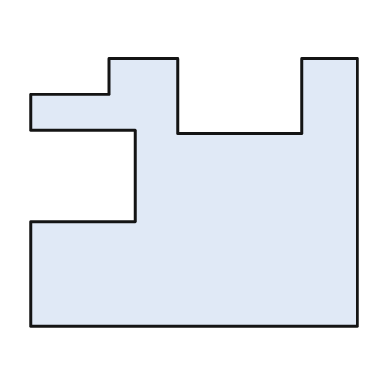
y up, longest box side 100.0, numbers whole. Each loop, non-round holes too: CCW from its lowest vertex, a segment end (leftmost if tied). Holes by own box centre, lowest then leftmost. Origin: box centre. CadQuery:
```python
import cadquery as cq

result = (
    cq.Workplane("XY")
    .moveTo(-50.0, -41.0)
    .lineTo(50.0, -41.0)
    .lineTo(50.0, 41.0)
    .lineTo(33.0, 41.0)
    .lineTo(33.0, 18.0)
    .lineTo(-5.0, 18.0)
    .lineTo(-5.0, 41.0)
    .lineTo(-26.0, 41.0)
    .lineTo(-26.0, 30.0)
    .lineTo(-50.0, 30.0)
    .lineTo(-50.0, 19.0)
    .lineTo(-18.0, 19.0)
    .lineTo(-18.0, -9.0)
    .lineTo(-50.0, -9.0)
    .close()
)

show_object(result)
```